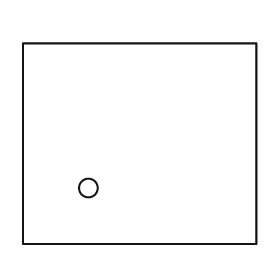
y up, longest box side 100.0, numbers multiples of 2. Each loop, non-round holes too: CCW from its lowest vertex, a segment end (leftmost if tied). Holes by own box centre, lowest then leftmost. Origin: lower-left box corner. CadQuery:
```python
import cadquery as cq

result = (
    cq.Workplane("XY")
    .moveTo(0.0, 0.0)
    .lineTo(100.0, 0.0)
    .lineTo(100.0, 86.0)
    .lineTo(0.0, 86.0)
    .close()
    .moveTo(28.0, 24.0)
    .circle(4.0)
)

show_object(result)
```